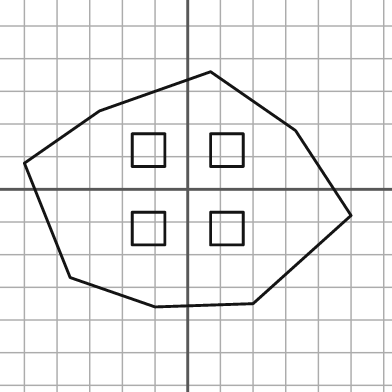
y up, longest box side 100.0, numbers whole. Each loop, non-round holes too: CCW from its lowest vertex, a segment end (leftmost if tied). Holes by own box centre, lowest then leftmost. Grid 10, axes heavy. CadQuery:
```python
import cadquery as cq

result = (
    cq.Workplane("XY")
    .moveTo(-10.0, -36.0)
    .lineTo(20.0, -35.0)
    .lineTo(50.0, -8.0)
    .lineTo(33.0, 18.0)
    .lineTo(7.0, 36.0)
    .lineTo(-27.0, 24.0)
    .lineTo(-50.0, 8.0)
    .lineTo(-36.0, -27.0)
    .close()
    .moveTo(-17.0, -17.0)
    .lineTo(-7.0, -17.0)
    .lineTo(-7.0, -7.0)
    .lineTo(-17.0, -7.0)
    .close()
    .moveTo(7.0, -17.0)
    .lineTo(17.0, -17.0)
    .lineTo(17.0, -7.0)
    .lineTo(7.0, -7.0)
    .close()
    .moveTo(-17.0, 7.0)
    .lineTo(-7.0, 7.0)
    .lineTo(-7.0, 17.0)
    .lineTo(-17.0, 17.0)
    .close()
    .moveTo(7.0, 7.0)
    .lineTo(17.0, 7.0)
    .lineTo(17.0, 17.0)
    .lineTo(7.0, 17.0)
    .close()
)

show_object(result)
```